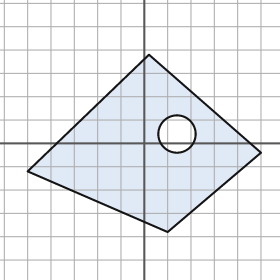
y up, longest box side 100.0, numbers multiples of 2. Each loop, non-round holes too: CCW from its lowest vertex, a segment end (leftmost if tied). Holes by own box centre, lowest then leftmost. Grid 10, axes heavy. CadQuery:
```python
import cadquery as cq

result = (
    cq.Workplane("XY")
    .moveTo(10.0, -38.0)
    .lineTo(50.0, -4.0)
    .lineTo(2.0, 38.0)
    .lineTo(-50.0, -12.0)
    .close()
    .moveTo(14.0, 4.0)
    .circle(8.0)
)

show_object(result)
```